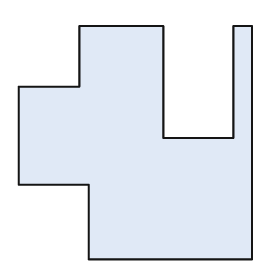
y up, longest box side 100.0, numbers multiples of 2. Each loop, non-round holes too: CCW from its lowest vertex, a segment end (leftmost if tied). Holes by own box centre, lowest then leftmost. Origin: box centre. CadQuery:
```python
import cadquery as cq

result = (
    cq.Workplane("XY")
    .moveTo(-20.0, -50.0)
    .lineTo(50.0, -50.0)
    .lineTo(50.0, 50.0)
    .lineTo(42.0, 50.0)
    .lineTo(42.0, 2.0)
    .lineTo(12.0, 2.0)
    .lineTo(12.0, 50.0)
    .lineTo(-24.0, 50.0)
    .lineTo(-24.0, 24.0)
    .lineTo(-50.0, 24.0)
    .lineTo(-50.0, -18.0)
    .lineTo(-20.0, -18.0)
    .close()
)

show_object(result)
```